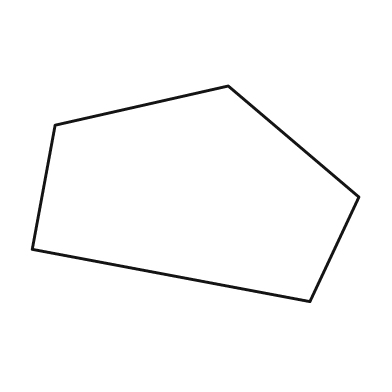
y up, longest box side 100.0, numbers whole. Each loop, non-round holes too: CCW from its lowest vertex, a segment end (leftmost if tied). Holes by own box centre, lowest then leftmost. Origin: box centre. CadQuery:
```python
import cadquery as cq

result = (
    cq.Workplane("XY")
    .moveTo(35.0, -33.0)
    .lineTo(50.0, -1.0)
    .lineTo(10.0, 33.0)
    .lineTo(-43.0, 21.0)
    .lineTo(-50.0, -17.0)
    .close()
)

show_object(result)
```